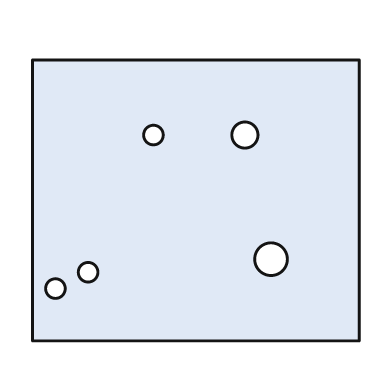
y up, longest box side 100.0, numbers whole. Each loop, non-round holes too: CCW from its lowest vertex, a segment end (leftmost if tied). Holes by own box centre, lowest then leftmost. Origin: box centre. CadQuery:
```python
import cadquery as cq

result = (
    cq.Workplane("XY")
    .moveTo(-50.0, -43.0)
    .lineTo(50.0, -43.0)
    .lineTo(50.0, 43.0)
    .lineTo(-50.0, 43.0)
    .close()
    .moveTo(-43.0, -27.0)
    .circle(3.0)
    .moveTo(-33.0, -22.0)
    .circle(3.0)
    .moveTo(23.0, -18.0)
    .circle(5.0)
    .moveTo(-13.0, 20.0)
    .circle(3.0)
    .moveTo(15.0, 20.0)
    .circle(4.0)
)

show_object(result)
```